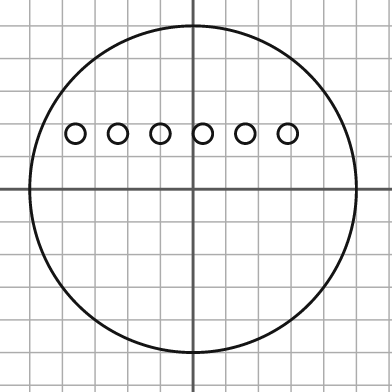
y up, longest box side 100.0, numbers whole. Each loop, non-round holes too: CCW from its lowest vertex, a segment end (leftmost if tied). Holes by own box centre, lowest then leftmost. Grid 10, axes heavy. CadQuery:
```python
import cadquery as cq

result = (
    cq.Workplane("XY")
    .moveTo(0.0, 0.0)
    .circle(50.0)
    .moveTo(-36.0, 17.0)
    .circle(3.0)
    .moveTo(-23.0, 17.0)
    .circle(3.0)
    .moveTo(-10.0, 17.0)
    .circle(3.0)
    .moveTo(3.0, 17.0)
    .circle(3.0)
    .moveTo(16.0, 17.0)
    .circle(3.0)
    .moveTo(29.0, 17.0)
    .circle(3.0)
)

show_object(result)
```